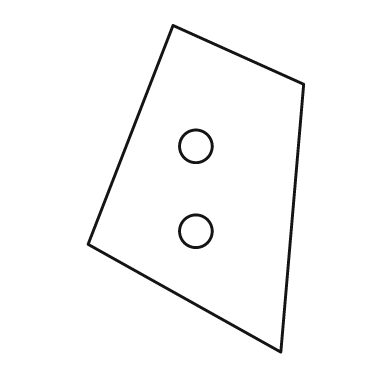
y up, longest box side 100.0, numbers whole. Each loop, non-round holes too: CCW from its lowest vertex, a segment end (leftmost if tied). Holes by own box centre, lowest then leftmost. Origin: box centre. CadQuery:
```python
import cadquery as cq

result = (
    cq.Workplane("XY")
    .moveTo(26.0, -50.0)
    .lineTo(33.0, 32.0)
    .lineTo(-7.0, 50.0)
    .lineTo(-33.0, -17.0)
    .close()
    .moveTo(0.0, -13.0)
    .circle(5.0)
    .moveTo(0.0, 13.0)
    .circle(5.0)
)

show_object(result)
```